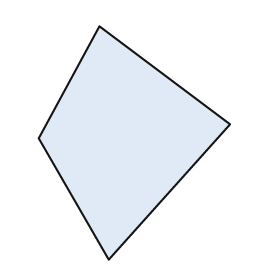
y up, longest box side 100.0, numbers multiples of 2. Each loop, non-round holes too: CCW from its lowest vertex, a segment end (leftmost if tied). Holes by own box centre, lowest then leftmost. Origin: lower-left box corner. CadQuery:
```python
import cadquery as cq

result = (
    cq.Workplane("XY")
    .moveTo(30.0, 0.0)
    .lineTo(82.0, 58.0)
    .lineTo(26.0, 100.0)
    .lineTo(0.0, 52.0)
    .close()
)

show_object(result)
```